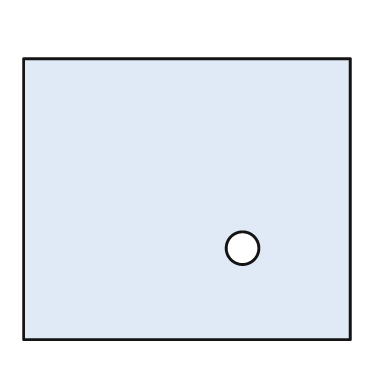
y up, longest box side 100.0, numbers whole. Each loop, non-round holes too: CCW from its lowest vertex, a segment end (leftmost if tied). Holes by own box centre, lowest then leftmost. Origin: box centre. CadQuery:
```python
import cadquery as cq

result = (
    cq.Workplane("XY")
    .moveTo(-50.0, -43.0)
    .lineTo(50.0, -43.0)
    .lineTo(50.0, 43.0)
    .lineTo(-50.0, 43.0)
    .close()
    .moveTo(17.0, -15.0)
    .circle(5.0)
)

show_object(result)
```